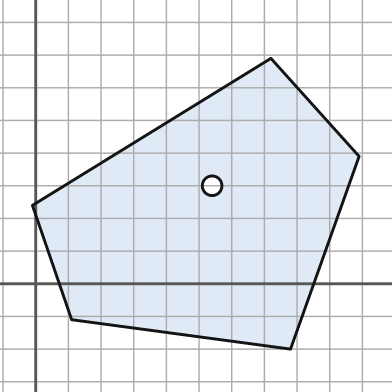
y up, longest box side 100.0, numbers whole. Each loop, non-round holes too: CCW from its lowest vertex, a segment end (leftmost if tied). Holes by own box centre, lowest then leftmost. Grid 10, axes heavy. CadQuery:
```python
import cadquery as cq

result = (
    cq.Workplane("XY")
    .moveTo(78.0, -20.0)
    .lineTo(99.0, 39.0)
    .lineTo(72.0, 69.0)
    .lineTo(-1.0, 24.0)
    .lineTo(11.0, -11.0)
    .close()
    .moveTo(54.0, 30.0)
    .circle(3.0)
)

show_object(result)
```